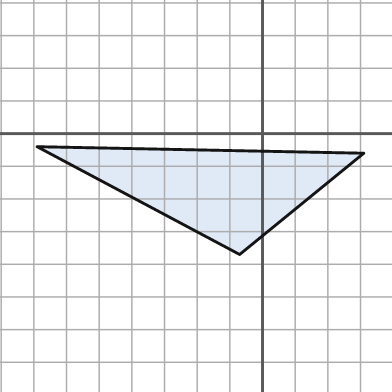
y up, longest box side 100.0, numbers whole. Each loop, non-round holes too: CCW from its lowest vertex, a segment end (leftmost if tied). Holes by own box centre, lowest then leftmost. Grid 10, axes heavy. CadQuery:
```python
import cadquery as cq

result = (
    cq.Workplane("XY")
    .moveTo(-7.0, -37.0)
    .lineTo(31.0, -6.0)
    .lineTo(-69.0, -4.0)
    .close()
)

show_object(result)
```